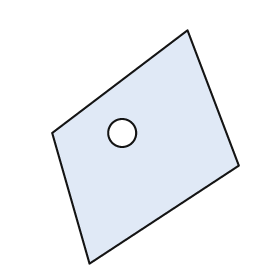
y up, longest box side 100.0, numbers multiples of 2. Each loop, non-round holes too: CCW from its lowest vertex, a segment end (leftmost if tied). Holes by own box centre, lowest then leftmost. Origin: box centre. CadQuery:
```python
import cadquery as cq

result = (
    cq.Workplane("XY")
    .moveTo(-24.0, -50.0)
    .lineTo(40.0, -8.0)
    .lineTo(18.0, 50.0)
    .lineTo(-40.0, 6.0)
    .close()
    .moveTo(-10.0, 6.0)
    .circle(6.0)
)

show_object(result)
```